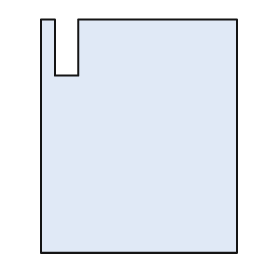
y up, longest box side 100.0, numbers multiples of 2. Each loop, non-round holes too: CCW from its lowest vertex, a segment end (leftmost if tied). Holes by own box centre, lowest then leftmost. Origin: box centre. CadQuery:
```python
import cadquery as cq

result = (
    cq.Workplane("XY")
    .moveTo(-42.0, -50.0)
    .lineTo(42.0, -50.0)
    .lineTo(42.0, 50.0)
    .lineTo(-26.0, 50.0)
    .lineTo(-26.0, 26.0)
    .lineTo(-36.0, 26.0)
    .lineTo(-36.0, 50.0)
    .lineTo(-42.0, 50.0)
    .close()
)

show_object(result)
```